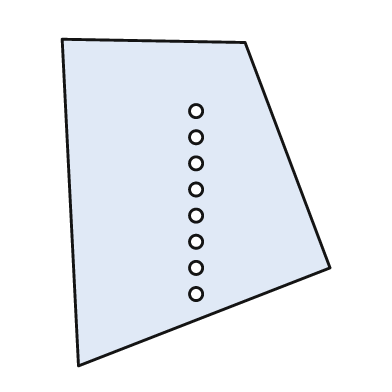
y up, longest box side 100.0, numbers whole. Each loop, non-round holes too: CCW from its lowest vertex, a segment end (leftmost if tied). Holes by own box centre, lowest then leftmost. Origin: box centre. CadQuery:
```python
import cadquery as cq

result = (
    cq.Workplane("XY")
    .moveTo(-36.0, -50.0)
    .lineTo(41.0, -20.0)
    .lineTo(15.0, 49.0)
    .lineTo(-41.0, 50.0)
    .close()
    .moveTo(0.0, -28.0)
    .circle(2.0)
    .moveTo(0.0, -20.0)
    .circle(2.0)
    .moveTo(0.0, -12.0)
    .circle(2.0)
    .moveTo(0.0, -4.0)
    .circle(2.0)
    .moveTo(0.0, 4.0)
    .circle(2.0)
    .moveTo(0.0, 12.0)
    .circle(2.0)
    .moveTo(0.0, 20.0)
    .circle(2.0)
    .moveTo(0.0, 28.0)
    .circle(2.0)
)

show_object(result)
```